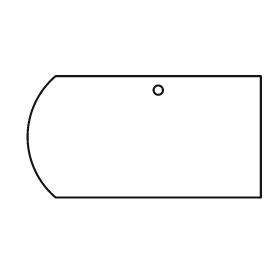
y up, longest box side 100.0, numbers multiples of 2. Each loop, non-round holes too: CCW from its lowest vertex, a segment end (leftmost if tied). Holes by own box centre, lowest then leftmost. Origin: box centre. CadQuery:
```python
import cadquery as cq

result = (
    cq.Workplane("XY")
    .moveTo(-38.0, -26.0)
    .lineTo(50.0, -26.0)
    .lineTo(50.0, 26.0)
    .lineTo(-38.0, 26.0)
    .threePointArc((-50.0, 0.0), (-38.0, -26.0))
    .close()
    .moveTo(6.0, 20.0)
    .circle(2.0)
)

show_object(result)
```